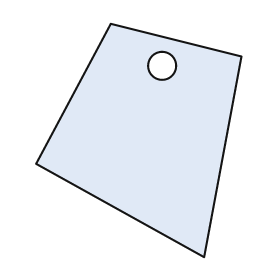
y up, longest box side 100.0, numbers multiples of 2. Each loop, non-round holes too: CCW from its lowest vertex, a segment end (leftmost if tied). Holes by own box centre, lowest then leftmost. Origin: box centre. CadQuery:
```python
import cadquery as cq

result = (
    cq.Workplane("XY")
    .moveTo(28.0, -50.0)
    .lineTo(44.0, 36.0)
    .lineTo(-12.0, 50.0)
    .lineTo(-44.0, -10.0)
    .close()
    .moveTo(10.0, 32.0)
    .circle(6.0)
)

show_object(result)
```